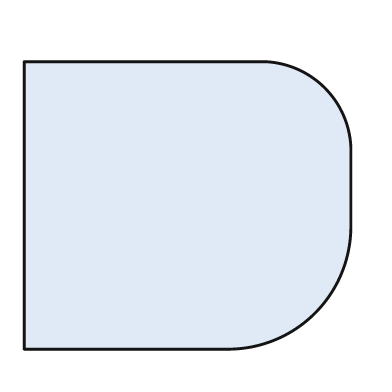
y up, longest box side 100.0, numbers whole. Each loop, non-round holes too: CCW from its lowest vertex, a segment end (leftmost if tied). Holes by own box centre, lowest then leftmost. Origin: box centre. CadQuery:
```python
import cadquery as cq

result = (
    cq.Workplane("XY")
    .moveTo(-50.0, -44.0)
    .lineTo(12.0, -44.0)
    .threePointArc((39.0, -33.0), (50.0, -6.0))
    .lineTo(50.0, 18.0)
    .threePointArc((42.0, 36.0), (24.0, 44.0))
    .lineTo(-50.0, 44.0)
    .close()
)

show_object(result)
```